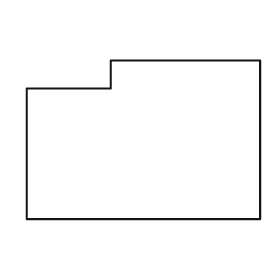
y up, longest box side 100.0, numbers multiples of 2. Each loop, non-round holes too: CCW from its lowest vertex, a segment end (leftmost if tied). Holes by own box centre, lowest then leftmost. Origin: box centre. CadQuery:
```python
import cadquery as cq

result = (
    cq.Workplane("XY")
    .moveTo(-50.0, -34.0)
    .lineTo(50.0, -34.0)
    .lineTo(50.0, 34.0)
    .lineTo(-14.0, 34.0)
    .lineTo(-14.0, 22.0)
    .lineTo(-50.0, 22.0)
    .close()
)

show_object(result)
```